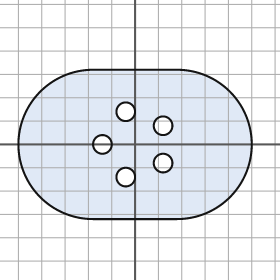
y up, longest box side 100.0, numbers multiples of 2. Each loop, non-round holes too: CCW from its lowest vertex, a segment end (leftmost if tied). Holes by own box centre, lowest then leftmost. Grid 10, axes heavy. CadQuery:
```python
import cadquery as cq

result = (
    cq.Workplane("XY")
    .moveTo(-18.0, -32.0)
    .lineTo(18.0, -32.0)
    .threePointArc((50.0, 0.0), (18.0, 32.0))
    .lineTo(-18.0, 32.0)
    .threePointArc((-50.0, 0.0), (-18.0, -32.0))
    .close()
    .moveTo(-4.0, -14.0)
    .circle(4.0)
    .moveTo(12.0, -8.0)
    .circle(4.0)
    .moveTo(-14.0, 0.0)
    .circle(4.0)
    .moveTo(12.0, 8.0)
    .circle(4.0)
    .moveTo(-4.0, 14.0)
    .circle(4.0)
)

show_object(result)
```